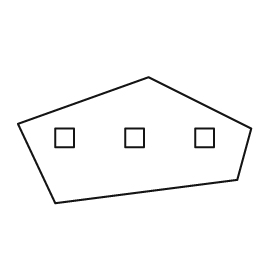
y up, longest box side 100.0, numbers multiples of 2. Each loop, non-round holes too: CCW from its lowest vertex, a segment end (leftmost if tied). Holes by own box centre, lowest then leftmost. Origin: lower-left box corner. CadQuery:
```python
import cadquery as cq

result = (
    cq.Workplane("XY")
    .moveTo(16.0, 0.0)
    .lineTo(94.0, 10.0)
    .lineTo(100.0, 32.0)
    .lineTo(56.0, 54.0)
    .lineTo(0.0, 34.0)
    .close()
    .moveTo(16.0, 24.0)
    .lineTo(24.0, 24.0)
    .lineTo(24.0, 32.0)
    .lineTo(16.0, 32.0)
    .close()
    .moveTo(46.0, 24.0)
    .lineTo(54.0, 24.0)
    .lineTo(54.0, 32.0)
    .lineTo(46.0, 32.0)
    .close()
    .moveTo(76.0, 24.0)
    .lineTo(84.0, 24.0)
    .lineTo(84.0, 32.0)
    .lineTo(76.0, 32.0)
    .close()
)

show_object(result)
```